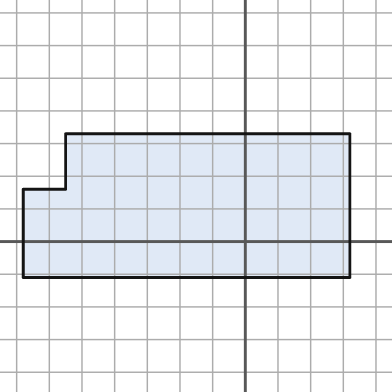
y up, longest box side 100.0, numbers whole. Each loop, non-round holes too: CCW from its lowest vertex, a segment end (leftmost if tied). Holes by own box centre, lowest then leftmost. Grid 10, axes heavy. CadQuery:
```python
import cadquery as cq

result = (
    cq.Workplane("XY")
    .moveTo(-68.0, -11.0)
    .lineTo(32.0, -11.0)
    .lineTo(32.0, 33.0)
    .lineTo(-55.0, 33.0)
    .lineTo(-55.0, 16.0)
    .lineTo(-68.0, 16.0)
    .close()
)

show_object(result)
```